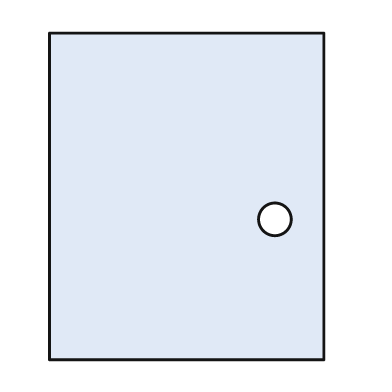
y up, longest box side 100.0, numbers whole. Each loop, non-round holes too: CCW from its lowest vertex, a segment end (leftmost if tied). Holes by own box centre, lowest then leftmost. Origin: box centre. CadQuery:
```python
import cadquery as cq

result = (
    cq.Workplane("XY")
    .moveTo(-42.0, -50.0)
    .lineTo(42.0, -50.0)
    .lineTo(42.0, 50.0)
    .lineTo(-42.0, 50.0)
    .close()
    .moveTo(27.0, -7.0)
    .circle(5.0)
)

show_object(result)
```